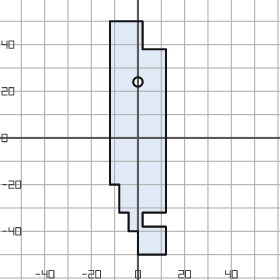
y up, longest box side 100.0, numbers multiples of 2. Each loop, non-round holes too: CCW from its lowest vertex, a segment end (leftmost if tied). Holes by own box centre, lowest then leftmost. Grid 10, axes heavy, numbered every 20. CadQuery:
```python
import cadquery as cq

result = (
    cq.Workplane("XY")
    .moveTo(0.0, -50.0)
    .lineTo(12.0, -50.0)
    .lineTo(12.0, -38.0)
    .lineTo(2.0, -38.0)
    .lineTo(2.0, -32.0)
    .lineTo(12.0, -32.0)
    .lineTo(12.0, 38.0)
    .lineTo(2.0, 38.0)
    .lineTo(2.0, 50.0)
    .lineTo(-12.0, 50.0)
    .lineTo(-12.0, -20.0)
    .lineTo(-8.0, -20.0)
    .lineTo(-8.0, -32.0)
    .lineTo(-4.0, -32.0)
    .lineTo(-4.0, -40.0)
    .lineTo(0.0, -40.0)
    .close()
    .moveTo(0.0, 24.0)
    .circle(2.0)
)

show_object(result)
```